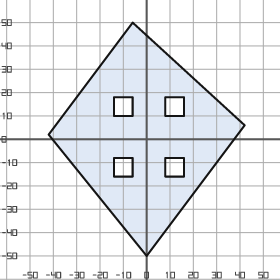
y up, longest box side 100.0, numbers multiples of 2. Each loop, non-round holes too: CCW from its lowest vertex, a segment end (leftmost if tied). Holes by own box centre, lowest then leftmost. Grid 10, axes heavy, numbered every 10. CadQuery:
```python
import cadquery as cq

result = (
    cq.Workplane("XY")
    .moveTo(0.0, -50.0)
    .lineTo(42.0, 6.0)
    .lineTo(-6.0, 50.0)
    .lineTo(-42.0, 2.0)
    .close()
    .moveTo(-14.0, -16.0)
    .lineTo(-6.0, -16.0)
    .lineTo(-6.0, -8.0)
    .lineTo(-14.0, -8.0)
    .close()
    .moveTo(8.0, -16.0)
    .lineTo(16.0, -16.0)
    .lineTo(16.0, -8.0)
    .lineTo(8.0, -8.0)
    .close()
    .moveTo(-14.0, 10.0)
    .lineTo(-6.0, 10.0)
    .lineTo(-6.0, 18.0)
    .lineTo(-14.0, 18.0)
    .close()
    .moveTo(8.0, 10.0)
    .lineTo(16.0, 10.0)
    .lineTo(16.0, 18.0)
    .lineTo(8.0, 18.0)
    .close()
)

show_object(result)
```